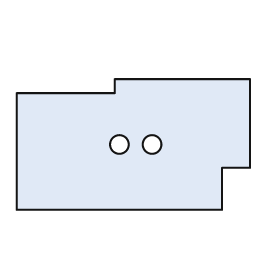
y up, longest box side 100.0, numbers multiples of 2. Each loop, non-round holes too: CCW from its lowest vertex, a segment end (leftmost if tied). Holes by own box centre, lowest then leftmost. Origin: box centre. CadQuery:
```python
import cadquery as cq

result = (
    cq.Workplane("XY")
    .moveTo(-50.0, -28.0)
    .lineTo(38.0, -28.0)
    .lineTo(38.0, -10.0)
    .lineTo(50.0, -10.0)
    .lineTo(50.0, 28.0)
    .lineTo(-8.0, 28.0)
    .lineTo(-8.0, 22.0)
    .lineTo(-50.0, 22.0)
    .close()
    .moveTo(-6.0, 0.0)
    .circle(4.0)
    .moveTo(8.0, 0.0)
    .circle(4.0)
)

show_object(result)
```